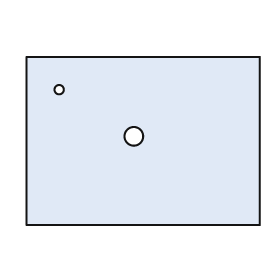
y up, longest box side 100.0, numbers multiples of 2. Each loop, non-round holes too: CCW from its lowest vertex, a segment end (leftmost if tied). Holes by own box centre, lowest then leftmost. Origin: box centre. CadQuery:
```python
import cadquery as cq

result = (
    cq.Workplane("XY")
    .moveTo(-50.0, -36.0)
    .lineTo(50.0, -36.0)
    .lineTo(50.0, 36.0)
    .lineTo(-50.0, 36.0)
    .close()
    .moveTo(-4.0, 2.0)
    .circle(4.0)
    .moveTo(-36.0, 22.0)
    .circle(2.0)
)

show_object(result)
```